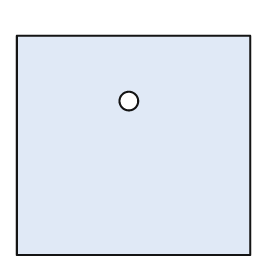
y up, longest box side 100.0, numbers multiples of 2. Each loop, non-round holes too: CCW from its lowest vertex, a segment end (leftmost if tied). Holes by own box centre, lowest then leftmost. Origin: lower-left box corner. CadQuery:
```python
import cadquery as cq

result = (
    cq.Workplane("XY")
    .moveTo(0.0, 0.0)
    .lineTo(100.0, 0.0)
    .lineTo(100.0, 94.0)
    .lineTo(0.0, 94.0)
    .close()
    .moveTo(48.0, 66.0)
    .circle(4.0)
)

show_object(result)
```